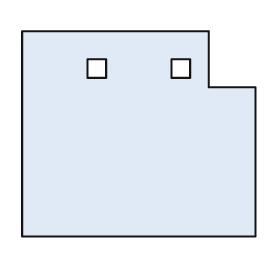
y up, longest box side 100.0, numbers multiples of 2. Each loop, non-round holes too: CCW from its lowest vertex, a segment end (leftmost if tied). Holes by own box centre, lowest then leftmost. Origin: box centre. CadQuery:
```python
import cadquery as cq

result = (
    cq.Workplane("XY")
    .moveTo(-50.0, -44.0)
    .lineTo(50.0, -44.0)
    .lineTo(50.0, 20.0)
    .lineTo(30.0, 20.0)
    .lineTo(30.0, 44.0)
    .lineTo(-50.0, 44.0)
    .close()
    .moveTo(-22.0, 24.0)
    .lineTo(-14.0, 24.0)
    .lineTo(-14.0, 32.0)
    .lineTo(-22.0, 32.0)
    .close()
    .moveTo(14.0, 24.0)
    .lineTo(22.0, 24.0)
    .lineTo(22.0, 32.0)
    .lineTo(14.0, 32.0)
    .close()
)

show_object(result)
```